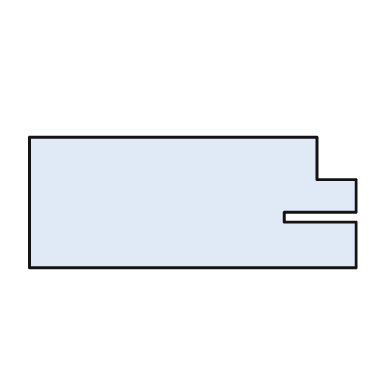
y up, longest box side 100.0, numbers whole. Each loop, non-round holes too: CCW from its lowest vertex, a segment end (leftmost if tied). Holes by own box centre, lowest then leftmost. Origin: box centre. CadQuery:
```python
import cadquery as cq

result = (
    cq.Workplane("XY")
    .moveTo(-50.0, -20.0)
    .lineTo(50.0, -20.0)
    .lineTo(50.0, -6.0)
    .lineTo(28.0, -6.0)
    .lineTo(28.0, -3.0)
    .lineTo(50.0, -3.0)
    .lineTo(50.0, 7.0)
    .lineTo(38.0, 7.0)
    .lineTo(38.0, 20.0)
    .lineTo(-50.0, 20.0)
    .close()
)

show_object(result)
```